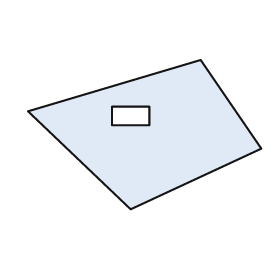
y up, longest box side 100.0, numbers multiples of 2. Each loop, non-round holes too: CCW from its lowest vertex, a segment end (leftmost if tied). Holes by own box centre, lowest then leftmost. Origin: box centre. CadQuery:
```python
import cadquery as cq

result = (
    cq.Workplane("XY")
    .moveTo(-6.0, -32.0)
    .lineTo(50.0, -6.0)
    .lineTo(24.0, 32.0)
    .lineTo(-50.0, 10.0)
    .close()
    .moveTo(-14.0, 4.0)
    .lineTo(2.0, 4.0)
    .lineTo(2.0, 12.0)
    .lineTo(-14.0, 12.0)
    .close()
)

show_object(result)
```